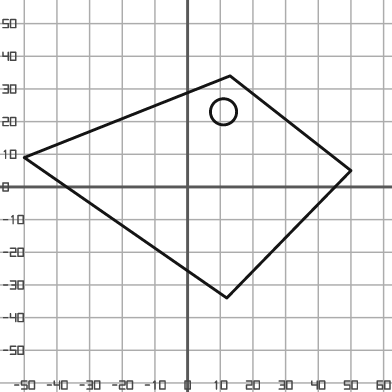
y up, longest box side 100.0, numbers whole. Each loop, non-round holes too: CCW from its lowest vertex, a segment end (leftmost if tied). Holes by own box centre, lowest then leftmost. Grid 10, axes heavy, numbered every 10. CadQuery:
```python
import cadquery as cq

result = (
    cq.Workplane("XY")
    .moveTo(12.0, -34.0)
    .lineTo(50.0, 5.0)
    .lineTo(13.0, 34.0)
    .lineTo(-50.0, 9.0)
    .close()
    .moveTo(11.0, 23.0)
    .circle(4.0)
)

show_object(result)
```